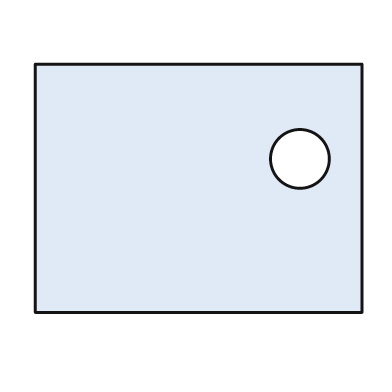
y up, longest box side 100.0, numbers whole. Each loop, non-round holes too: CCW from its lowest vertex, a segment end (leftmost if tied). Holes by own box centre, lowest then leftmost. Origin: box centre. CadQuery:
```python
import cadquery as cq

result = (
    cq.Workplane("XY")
    .moveTo(-50.0, -38.0)
    .lineTo(50.0, -38.0)
    .lineTo(50.0, 38.0)
    .lineTo(-50.0, 38.0)
    .close()
    .moveTo(31.0, 9.0)
    .circle(9.0)
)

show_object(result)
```